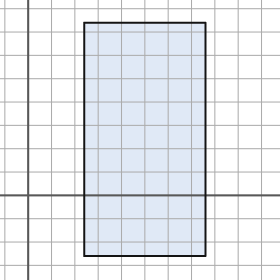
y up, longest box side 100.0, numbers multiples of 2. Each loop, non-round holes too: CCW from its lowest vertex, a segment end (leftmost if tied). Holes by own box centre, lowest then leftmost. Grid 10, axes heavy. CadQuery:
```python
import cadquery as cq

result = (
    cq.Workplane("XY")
    .moveTo(24.0, -26.0)
    .lineTo(76.0, -26.0)
    .lineTo(76.0, 74.0)
    .lineTo(24.0, 74.0)
    .close()
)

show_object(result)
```